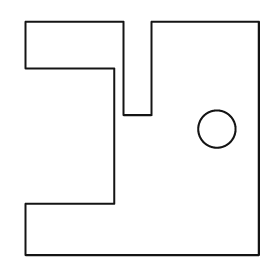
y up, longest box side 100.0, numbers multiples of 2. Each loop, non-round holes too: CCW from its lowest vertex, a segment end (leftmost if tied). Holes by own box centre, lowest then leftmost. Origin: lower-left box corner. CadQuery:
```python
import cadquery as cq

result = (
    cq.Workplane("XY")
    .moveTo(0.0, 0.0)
    .lineTo(100.0, 0.0)
    .lineTo(100.0, 100.0)
    .lineTo(54.0, 100.0)
    .lineTo(54.0, 60.0)
    .lineTo(42.0, 60.0)
    .lineTo(42.0, 100.0)
    .lineTo(0.0, 100.0)
    .lineTo(0.0, 80.0)
    .lineTo(38.0, 80.0)
    .lineTo(38.0, 22.0)
    .lineTo(0.0, 22.0)
    .close()
    .moveTo(82.0, 54.0)
    .circle(8.0)
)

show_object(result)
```